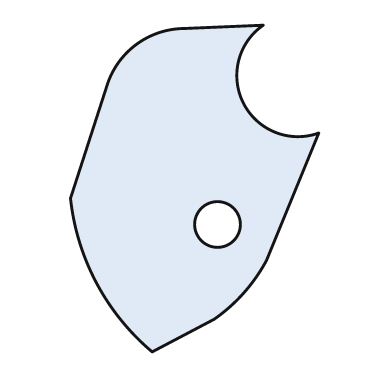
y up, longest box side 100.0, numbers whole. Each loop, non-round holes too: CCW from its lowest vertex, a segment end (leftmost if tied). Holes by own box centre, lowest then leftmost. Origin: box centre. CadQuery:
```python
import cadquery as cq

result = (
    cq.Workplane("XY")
    .moveTo(-13.0, -50.0)
    .lineTo(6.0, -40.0)
    .threePointArc((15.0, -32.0), (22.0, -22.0))
    .lineTo(38.0, 17.0)
    .threePointArc((15.0, 26.0), (21.0, 50.0))
    .lineTo(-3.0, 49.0)
    .threePointArc((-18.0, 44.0), (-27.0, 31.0))
    .lineTo(-38.0, -3.0)
    .threePointArc((-30.0, -29.0), (-13.0, -50.0))
    .close()
    .moveTo(7.0, -11.0)
    .circle(7.0)
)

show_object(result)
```